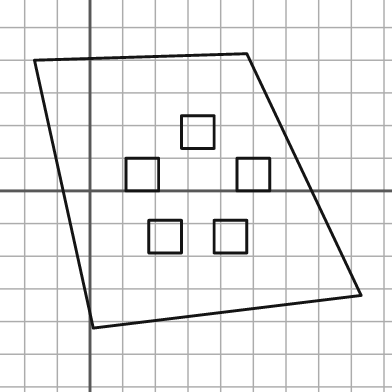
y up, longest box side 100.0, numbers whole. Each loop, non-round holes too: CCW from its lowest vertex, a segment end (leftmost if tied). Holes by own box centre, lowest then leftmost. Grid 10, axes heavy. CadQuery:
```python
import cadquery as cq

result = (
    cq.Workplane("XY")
    .moveTo(1.0, -42.0)
    .lineTo(83.0, -32.0)
    .lineTo(48.0, 42.0)
    .lineTo(-17.0, 40.0)
    .close()
    .moveTo(18.0, -19.0)
    .lineTo(28.0, -19.0)
    .lineTo(28.0, -9.0)
    .lineTo(18.0, -9.0)
    .close()
    .moveTo(38.0, -19.0)
    .lineTo(48.0, -19.0)
    .lineTo(48.0, -9.0)
    .lineTo(38.0, -9.0)
    .close()
    .moveTo(11.0, 0.0)
    .lineTo(21.0, 0.0)
    .lineTo(21.0, 10.0)
    .lineTo(11.0, 10.0)
    .close()
    .moveTo(45.0, 0.0)
    .lineTo(55.0, 0.0)
    .lineTo(55.0, 10.0)
    .lineTo(45.0, 10.0)
    .close()
    .moveTo(28.0, 13.0)
    .lineTo(38.0, 13.0)
    .lineTo(38.0, 23.0)
    .lineTo(28.0, 23.0)
    .close()
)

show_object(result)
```